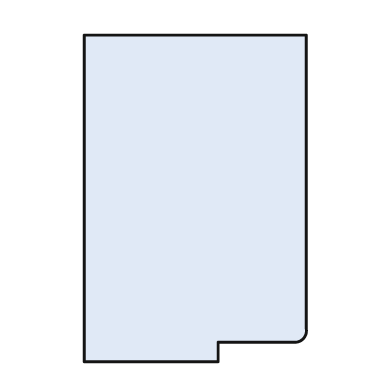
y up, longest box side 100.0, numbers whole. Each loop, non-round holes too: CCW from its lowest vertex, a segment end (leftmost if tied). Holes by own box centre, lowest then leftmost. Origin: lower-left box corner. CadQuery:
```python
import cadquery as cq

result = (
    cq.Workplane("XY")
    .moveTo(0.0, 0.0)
    .lineTo(41.0, 0.0)
    .lineTo(41.0, 6.0)
    .lineTo(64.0, 6.0)
    .threePointArc((67.0, 7.0), (68.0, 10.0))
    .lineTo(68.0, 100.0)
    .lineTo(0.0, 100.0)
    .close()
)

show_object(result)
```